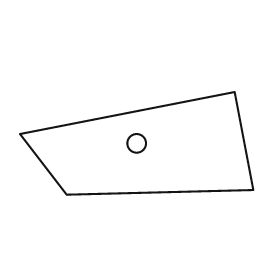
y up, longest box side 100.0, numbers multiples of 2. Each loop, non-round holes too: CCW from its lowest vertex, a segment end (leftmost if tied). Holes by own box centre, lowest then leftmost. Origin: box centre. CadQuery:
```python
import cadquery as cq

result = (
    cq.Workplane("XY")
    .moveTo(-30.0, -22.0)
    .lineTo(50.0, -20.0)
    .lineTo(42.0, 22.0)
    .lineTo(-50.0, 4.0)
    .close()
    .moveTo(0.0, 0.0)
    .circle(4.0)
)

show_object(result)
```